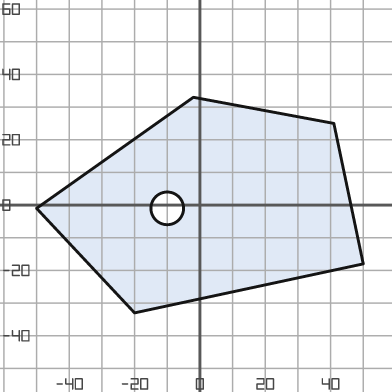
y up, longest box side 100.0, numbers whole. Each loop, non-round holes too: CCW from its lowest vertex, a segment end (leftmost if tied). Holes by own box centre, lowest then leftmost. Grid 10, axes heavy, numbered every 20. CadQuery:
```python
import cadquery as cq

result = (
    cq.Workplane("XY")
    .moveTo(-20.0, -33.0)
    .lineTo(50.0, -18.0)
    .lineTo(41.0, 25.0)
    .lineTo(-2.0, 33.0)
    .lineTo(-50.0, -1.0)
    .close()
    .moveTo(-10.0, -1.0)
    .circle(5.0)
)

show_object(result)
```